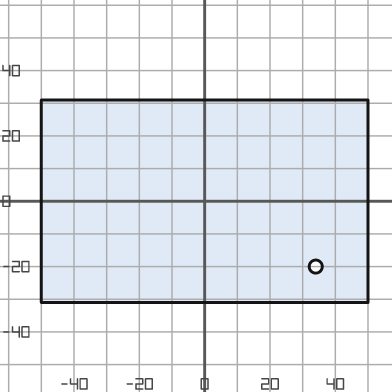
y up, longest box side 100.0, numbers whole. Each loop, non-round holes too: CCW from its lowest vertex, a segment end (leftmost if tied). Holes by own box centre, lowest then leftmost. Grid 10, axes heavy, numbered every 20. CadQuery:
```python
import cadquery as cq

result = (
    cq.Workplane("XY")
    .moveTo(-50.0, -31.0)
    .lineTo(50.0, -31.0)
    .lineTo(50.0, 31.0)
    .lineTo(-50.0, 31.0)
    .close()
    .moveTo(34.0, -20.0)
    .circle(2.0)
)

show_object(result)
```